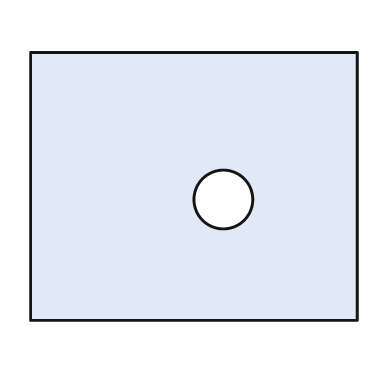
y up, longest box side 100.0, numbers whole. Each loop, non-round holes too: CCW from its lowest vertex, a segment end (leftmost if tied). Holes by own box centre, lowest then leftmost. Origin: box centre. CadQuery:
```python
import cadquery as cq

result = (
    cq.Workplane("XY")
    .moveTo(-50.0, -41.0)
    .lineTo(50.0, -41.0)
    .lineTo(50.0, 41.0)
    .lineTo(-50.0, 41.0)
    .close()
    .moveTo(9.0, -4.0)
    .circle(9.0)
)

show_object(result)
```